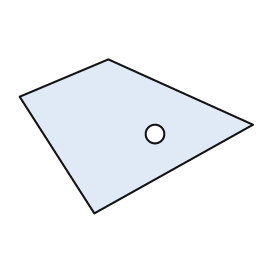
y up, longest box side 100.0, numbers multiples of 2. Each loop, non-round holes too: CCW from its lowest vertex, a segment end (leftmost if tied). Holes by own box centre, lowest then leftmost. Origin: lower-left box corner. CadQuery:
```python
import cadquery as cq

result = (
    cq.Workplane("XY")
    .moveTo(32.0, 0.0)
    .lineTo(100.0, 38.0)
    .lineTo(38.0, 66.0)
    .lineTo(0.0, 50.0)
    .close()
    .moveTo(58.0, 34.0)
    .circle(4.0)
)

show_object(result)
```